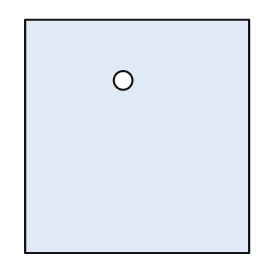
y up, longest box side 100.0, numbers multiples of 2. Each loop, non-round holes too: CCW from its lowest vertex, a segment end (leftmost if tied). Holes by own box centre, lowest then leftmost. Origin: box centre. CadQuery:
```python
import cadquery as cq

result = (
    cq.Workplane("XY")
    .moveTo(-48.0, -50.0)
    .lineTo(48.0, -50.0)
    .lineTo(48.0, 50.0)
    .lineTo(-48.0, 50.0)
    .close()
    .moveTo(-6.0, 24.0)
    .circle(4.0)
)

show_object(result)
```